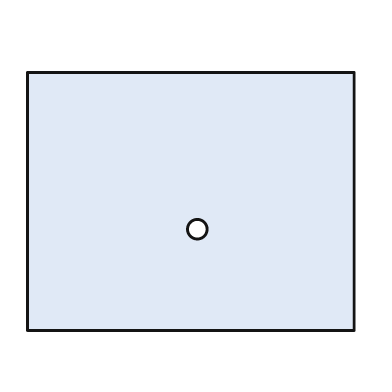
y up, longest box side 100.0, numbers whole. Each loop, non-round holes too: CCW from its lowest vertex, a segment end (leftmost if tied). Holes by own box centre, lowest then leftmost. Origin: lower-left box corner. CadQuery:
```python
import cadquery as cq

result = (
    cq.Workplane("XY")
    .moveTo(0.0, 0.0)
    .lineTo(100.0, 0.0)
    .lineTo(100.0, 79.0)
    .lineTo(0.0, 79.0)
    .close()
    .moveTo(52.0, 31.0)
    .circle(3.0)
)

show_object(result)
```